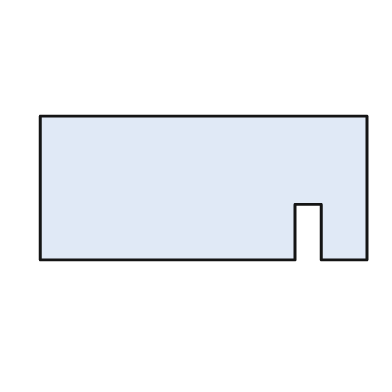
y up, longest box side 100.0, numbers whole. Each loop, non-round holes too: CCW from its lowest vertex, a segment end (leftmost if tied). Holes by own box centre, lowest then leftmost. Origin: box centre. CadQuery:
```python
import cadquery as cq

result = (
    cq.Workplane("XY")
    .moveTo(-50.0, -22.0)
    .lineTo(28.0, -22.0)
    .lineTo(28.0, -5.0)
    .lineTo(36.0, -5.0)
    .lineTo(36.0, -22.0)
    .lineTo(50.0, -22.0)
    .lineTo(50.0, 22.0)
    .lineTo(-50.0, 22.0)
    .close()
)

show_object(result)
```